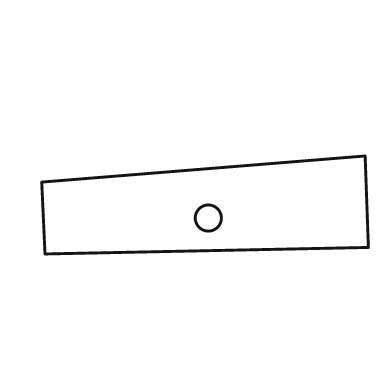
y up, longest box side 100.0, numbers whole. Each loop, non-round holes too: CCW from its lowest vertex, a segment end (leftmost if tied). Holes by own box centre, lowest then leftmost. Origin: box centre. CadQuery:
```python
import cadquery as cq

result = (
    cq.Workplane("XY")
    .moveTo(-49.0, -15.0)
    .lineTo(50.0, -13.0)
    .lineTo(49.0, 15.0)
    .lineTo(-50.0, 7.0)
    .close()
    .moveTo(1.0, -4.0)
    .circle(4.0)
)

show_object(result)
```